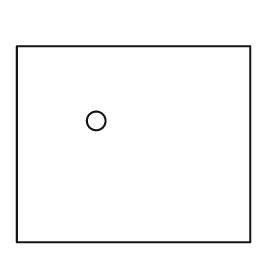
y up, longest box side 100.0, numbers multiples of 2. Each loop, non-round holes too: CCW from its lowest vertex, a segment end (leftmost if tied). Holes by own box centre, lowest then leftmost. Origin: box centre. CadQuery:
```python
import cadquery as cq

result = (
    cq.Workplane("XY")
    .moveTo(-50.0, -42.0)
    .lineTo(50.0, -42.0)
    .lineTo(50.0, 42.0)
    .lineTo(-50.0, 42.0)
    .close()
    .moveTo(-16.0, 10.0)
    .circle(4.0)
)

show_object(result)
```